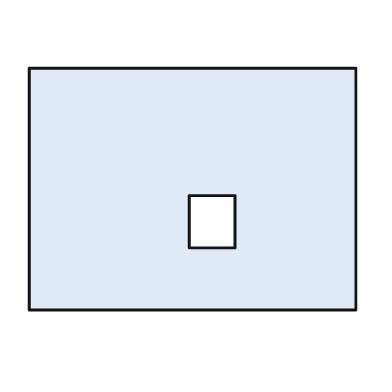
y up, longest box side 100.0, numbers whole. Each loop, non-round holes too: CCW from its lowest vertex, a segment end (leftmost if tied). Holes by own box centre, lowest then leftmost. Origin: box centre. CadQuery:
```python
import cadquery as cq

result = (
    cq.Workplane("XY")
    .moveTo(-50.0, -37.0)
    .lineTo(50.0, -37.0)
    .lineTo(50.0, 37.0)
    .lineTo(-50.0, 37.0)
    .close()
    .moveTo(-1.0, -18.0)
    .lineTo(13.0, -18.0)
    .lineTo(13.0, -2.0)
    .lineTo(-1.0, -2.0)
    .close()
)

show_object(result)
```